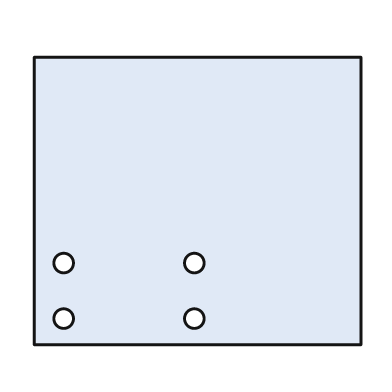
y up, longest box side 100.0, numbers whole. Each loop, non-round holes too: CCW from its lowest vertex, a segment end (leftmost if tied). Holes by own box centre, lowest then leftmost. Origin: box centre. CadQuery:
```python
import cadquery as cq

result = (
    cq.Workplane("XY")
    .moveTo(-50.0, -44.0)
    .lineTo(50.0, -44.0)
    .lineTo(50.0, 44.0)
    .lineTo(-50.0, 44.0)
    .close()
    .moveTo(-41.0, -36.0)
    .circle(3.0)
    .moveTo(-1.0, -36.0)
    .circle(3.0)
    .moveTo(-41.0, -19.0)
    .circle(3.0)
    .moveTo(-1.0, -19.0)
    .circle(3.0)
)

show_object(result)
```